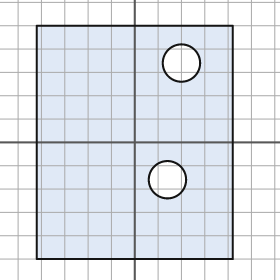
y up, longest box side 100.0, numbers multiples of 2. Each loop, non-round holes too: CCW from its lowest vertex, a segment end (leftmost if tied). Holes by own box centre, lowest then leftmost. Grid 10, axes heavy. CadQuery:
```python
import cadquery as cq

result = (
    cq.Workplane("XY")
    .moveTo(-42.0, -50.0)
    .lineTo(42.0, -50.0)
    .lineTo(42.0, 50.0)
    .lineTo(-42.0, 50.0)
    .close()
    .moveTo(14.0, -16.0)
    .circle(8.0)
    .moveTo(20.0, 34.0)
    .circle(8.0)
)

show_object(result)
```